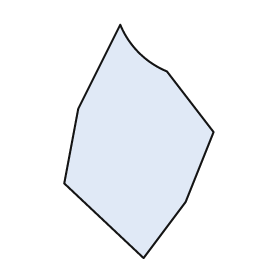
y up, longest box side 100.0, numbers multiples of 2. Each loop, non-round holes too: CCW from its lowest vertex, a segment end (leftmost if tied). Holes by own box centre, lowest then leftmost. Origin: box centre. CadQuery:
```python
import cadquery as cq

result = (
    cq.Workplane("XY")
    .moveTo(2.0, -50.0)
    .lineTo(20.0, -26.0)
    .lineTo(32.0, 4.0)
    .lineTo(12.0, 30.0)
    .threePointArc((0.0, 38.0), (-8.0, 50.0))
    .lineTo(-26.0, 14.0)
    .lineTo(-32.0, -18.0)
    .close()
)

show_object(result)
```